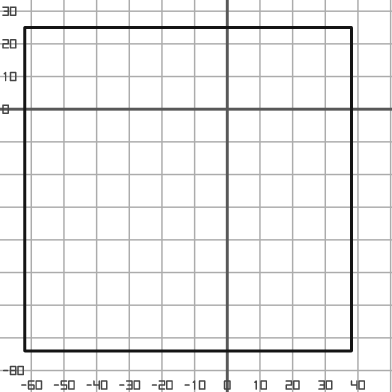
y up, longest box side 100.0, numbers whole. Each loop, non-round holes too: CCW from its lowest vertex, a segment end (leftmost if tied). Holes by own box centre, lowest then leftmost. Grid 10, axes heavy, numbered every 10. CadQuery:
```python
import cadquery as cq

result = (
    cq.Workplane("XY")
    .moveTo(-62.0, -74.0)
    .lineTo(38.0, -74.0)
    .lineTo(38.0, 25.0)
    .lineTo(-62.0, 25.0)
    .close()
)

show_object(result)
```